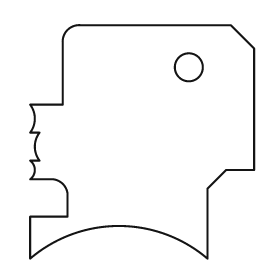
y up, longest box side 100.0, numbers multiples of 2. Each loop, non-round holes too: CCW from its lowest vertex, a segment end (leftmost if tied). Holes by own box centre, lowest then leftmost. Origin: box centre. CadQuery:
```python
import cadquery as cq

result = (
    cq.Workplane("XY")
    .moveTo(-48.0, -50.0)
    .threePointArc((-10.0, -36.0), (28.0, -50.0))
    .lineTo(28.0, -20.0)
    .lineTo(36.0, -12.0)
    .lineTo(48.0, -12.0)
    .lineTo(48.0, 40.0)
    .lineTo(38.0, 50.0)
    .lineTo(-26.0, 50.0)
    .threePointArc((-32.0, 48.0), (-34.0, 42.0))
    .lineTo(-34.0, 16.0)
    .lineTo(-48.0, 16.0)
    .threePointArc((-46.0, 10.0), (-48.0, 4.0))
    .lineTo(-44.0, 4.0)
    .threePointArc((-46.0, -2.0), (-44.0, -8.0))
    .lineTo(-48.0, -8.0)
    .threePointArc((-46.0, -12.0), (-48.0, -16.0))
    .lineTo(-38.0, -16.0)
    .threePointArc((-34.0, -18.0), (-32.0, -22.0))
    .lineTo(-32.0, -32.0)
    .lineTo(-48.0, -32.0)
    .close()
    .moveTo(20.0, 32.0)
    .circle(6.0)
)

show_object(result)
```